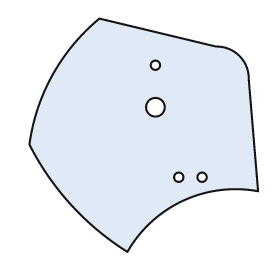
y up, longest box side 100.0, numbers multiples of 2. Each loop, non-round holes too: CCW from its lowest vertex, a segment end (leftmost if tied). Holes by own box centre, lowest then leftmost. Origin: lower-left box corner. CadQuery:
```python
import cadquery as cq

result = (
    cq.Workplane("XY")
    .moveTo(42.0, 0.0)
    .threePointArc((66.0, 22.0), (98.0, 26.0))
    .lineTo(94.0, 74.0)
    .threePointArc((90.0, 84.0), (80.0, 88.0))
    .lineTo(30.0, 100.0)
    .threePointArc((10.0, 76.0), (0.0, 46.0))
    .threePointArc((18.0, 20.0), (42.0, 0.0))
    .close()
    .moveTo(64.0, 32.0)
    .circle(2.0)
    .moveTo(74.0, 32.0)
    .circle(2.0)
    .moveTo(54.0, 62.0)
    .circle(4.0)
    .moveTo(54.0, 80.0)
    .circle(2.0)
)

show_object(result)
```